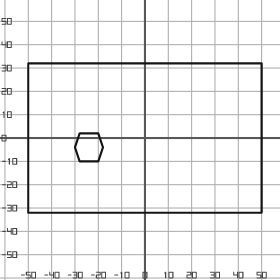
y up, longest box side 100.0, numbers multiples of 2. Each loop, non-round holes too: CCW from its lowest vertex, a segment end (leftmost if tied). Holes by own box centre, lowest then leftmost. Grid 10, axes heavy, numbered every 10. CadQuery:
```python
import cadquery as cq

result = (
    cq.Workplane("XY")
    .moveTo(-50.0, -32.0)
    .lineTo(50.0, -32.0)
    .lineTo(50.0, 32.0)
    .lineTo(-50.0, 32.0)
    .close()
    .moveTo(-28.0, -10.0)
    .lineTo(-20.0, -10.0)
    .lineTo(-18.0, -4.0)
    .lineTo(-20.0, 2.0)
    .lineTo(-28.0, 2.0)
    .lineTo(-30.0, -4.0)
    .close()
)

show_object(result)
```